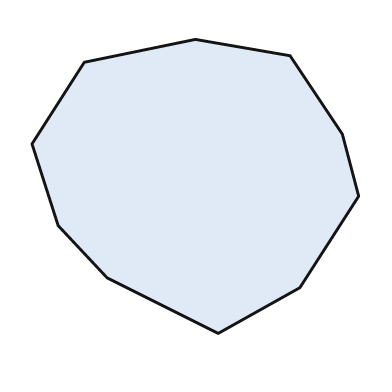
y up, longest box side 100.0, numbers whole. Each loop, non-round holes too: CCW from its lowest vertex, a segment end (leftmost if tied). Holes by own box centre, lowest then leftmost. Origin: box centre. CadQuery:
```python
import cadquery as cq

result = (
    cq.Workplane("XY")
    .moveTo(7.0, -45.0)
    .lineTo(32.0, -31.0)
    .lineTo(50.0, -3.0)
    .lineTo(45.0, 16.0)
    .lineTo(29.0, 40.0)
    .lineTo(0.0, 45.0)
    .lineTo(-34.0, 38.0)
    .lineTo(-50.0, 13.0)
    .lineTo(-42.0, -12.0)
    .lineTo(-27.0, -28.0)
    .close()
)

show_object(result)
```